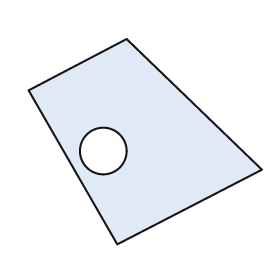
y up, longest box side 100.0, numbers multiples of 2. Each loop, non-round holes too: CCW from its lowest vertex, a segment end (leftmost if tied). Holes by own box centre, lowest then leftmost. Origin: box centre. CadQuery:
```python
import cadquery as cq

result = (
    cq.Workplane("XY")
    .moveTo(-12.0, -44.0)
    .lineTo(50.0, -12.0)
    .lineTo(-8.0, 44.0)
    .lineTo(-50.0, 22.0)
    .close()
    .moveTo(-18.0, -4.0)
    .circle(10.0)
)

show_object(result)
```